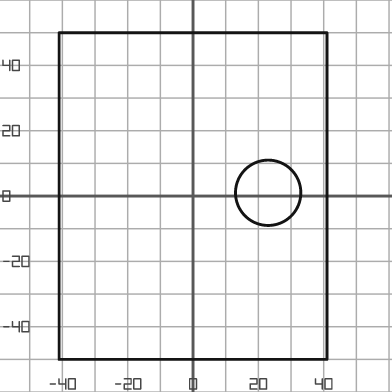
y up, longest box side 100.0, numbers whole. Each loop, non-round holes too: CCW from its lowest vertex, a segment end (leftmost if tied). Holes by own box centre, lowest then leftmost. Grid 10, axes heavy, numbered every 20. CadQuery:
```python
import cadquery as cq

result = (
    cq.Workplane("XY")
    .moveTo(-41.0, -50.0)
    .lineTo(41.0, -50.0)
    .lineTo(41.0, 50.0)
    .lineTo(-41.0, 50.0)
    .close()
    .moveTo(23.0, 1.0)
    .circle(10.0)
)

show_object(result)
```